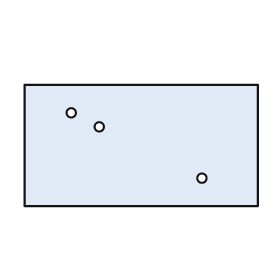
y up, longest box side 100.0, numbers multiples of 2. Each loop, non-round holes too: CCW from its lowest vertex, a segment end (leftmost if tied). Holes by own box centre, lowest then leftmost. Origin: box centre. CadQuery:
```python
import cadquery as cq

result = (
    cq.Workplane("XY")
    .moveTo(-50.0, -26.0)
    .lineTo(50.0, -26.0)
    .lineTo(50.0, 26.0)
    .lineTo(-50.0, 26.0)
    .close()
    .moveTo(26.0, -14.0)
    .circle(2.0)
    .moveTo(-18.0, 8.0)
    .circle(2.0)
    .moveTo(-30.0, 14.0)
    .circle(2.0)
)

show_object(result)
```